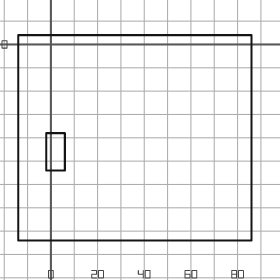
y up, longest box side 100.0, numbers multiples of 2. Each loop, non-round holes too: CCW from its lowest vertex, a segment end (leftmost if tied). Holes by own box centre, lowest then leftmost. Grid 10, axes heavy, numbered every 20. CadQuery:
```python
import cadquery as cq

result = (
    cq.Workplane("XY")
    .moveTo(-14.0, -84.0)
    .lineTo(86.0, -84.0)
    .lineTo(86.0, 4.0)
    .lineTo(-14.0, 4.0)
    .close()
    .moveTo(-2.0, -54.0)
    .lineTo(6.0, -54.0)
    .lineTo(6.0, -38.0)
    .lineTo(-2.0, -38.0)
    .close()
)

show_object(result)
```